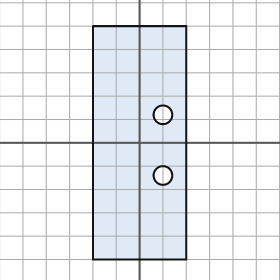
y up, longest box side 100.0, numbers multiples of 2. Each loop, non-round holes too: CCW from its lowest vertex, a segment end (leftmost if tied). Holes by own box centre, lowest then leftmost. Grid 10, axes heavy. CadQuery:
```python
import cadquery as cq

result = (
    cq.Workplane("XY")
    .moveTo(-20.0, -50.0)
    .lineTo(20.0, -50.0)
    .lineTo(20.0, 50.0)
    .lineTo(-20.0, 50.0)
    .close()
    .moveTo(10.0, -14.0)
    .circle(4.0)
    .moveTo(10.0, 12.0)
    .circle(4.0)
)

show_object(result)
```